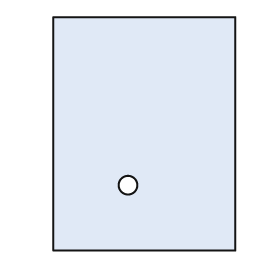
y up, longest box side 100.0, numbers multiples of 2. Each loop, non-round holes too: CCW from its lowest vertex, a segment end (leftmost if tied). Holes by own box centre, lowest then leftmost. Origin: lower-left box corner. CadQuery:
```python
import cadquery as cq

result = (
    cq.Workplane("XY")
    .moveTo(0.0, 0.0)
    .lineTo(78.0, 0.0)
    .lineTo(78.0, 100.0)
    .lineTo(0.0, 100.0)
    .close()
    .moveTo(32.0, 28.0)
    .circle(4.0)
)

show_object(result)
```